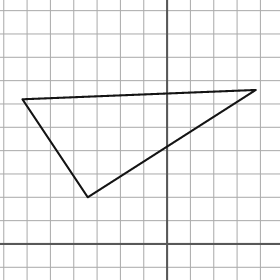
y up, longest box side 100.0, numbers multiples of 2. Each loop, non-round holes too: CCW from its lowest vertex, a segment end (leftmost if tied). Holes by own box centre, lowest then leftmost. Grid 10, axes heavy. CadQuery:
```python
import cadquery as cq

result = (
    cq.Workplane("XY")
    .moveTo(-34.0, 20.0)
    .lineTo(38.0, 66.0)
    .lineTo(-62.0, 62.0)
    .close()
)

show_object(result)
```